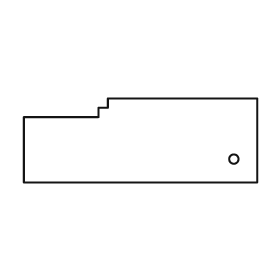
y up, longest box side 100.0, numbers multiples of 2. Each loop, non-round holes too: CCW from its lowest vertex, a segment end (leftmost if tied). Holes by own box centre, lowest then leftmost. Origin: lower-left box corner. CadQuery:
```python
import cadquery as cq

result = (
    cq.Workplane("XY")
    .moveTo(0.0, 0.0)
    .lineTo(100.0, 0.0)
    .lineTo(100.0, 36.0)
    .lineTo(36.0, 36.0)
    .lineTo(36.0, 32.0)
    .lineTo(32.0, 32.0)
    .lineTo(32.0, 28.0)
    .lineTo(0.0, 28.0)
    .close()
    .moveTo(90.0, 10.0)
    .circle(2.0)
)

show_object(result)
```